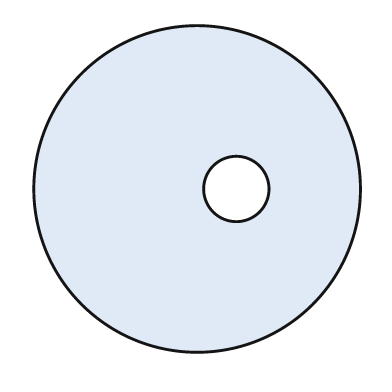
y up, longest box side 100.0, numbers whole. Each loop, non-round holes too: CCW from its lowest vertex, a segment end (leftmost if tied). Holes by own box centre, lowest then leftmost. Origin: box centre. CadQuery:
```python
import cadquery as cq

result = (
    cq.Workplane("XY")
    .moveTo(0.0, 0.0)
    .circle(50.0)
    .moveTo(12.0, 0.0)
    .circle(10.0)
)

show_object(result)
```